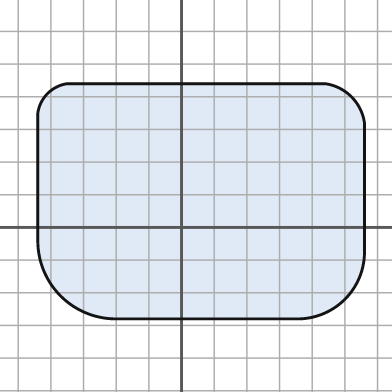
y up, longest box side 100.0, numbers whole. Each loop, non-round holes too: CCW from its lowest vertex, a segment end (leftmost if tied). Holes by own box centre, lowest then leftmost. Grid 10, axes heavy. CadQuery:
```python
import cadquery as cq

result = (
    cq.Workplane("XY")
    .moveTo(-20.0, -28.0)
    .lineTo(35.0, -28.0)
    .threePointArc((50.0, -22.0), (56.0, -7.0))
    .lineTo(56.0, 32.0)
    .threePointArc((52.0, 40.0), (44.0, 44.0))
    .lineTo(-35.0, 44.0)
    .threePointArc((-41.0, 41.0), (-44.0, 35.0))
    .lineTo(-44.0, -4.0)
    .threePointArc((-37.0, -21.0), (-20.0, -28.0))
    .close()
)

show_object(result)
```